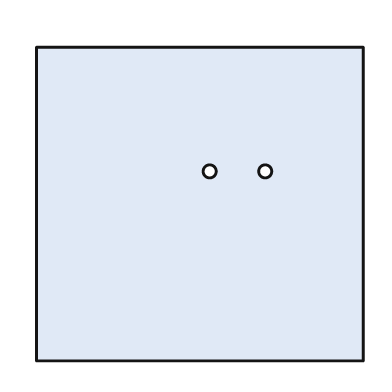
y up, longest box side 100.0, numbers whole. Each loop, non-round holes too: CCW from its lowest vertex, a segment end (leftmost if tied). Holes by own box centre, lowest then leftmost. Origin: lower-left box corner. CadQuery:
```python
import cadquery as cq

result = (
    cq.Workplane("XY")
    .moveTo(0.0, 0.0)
    .lineTo(100.0, 0.0)
    .lineTo(100.0, 96.0)
    .lineTo(0.0, 96.0)
    .close()
    .moveTo(53.0, 58.0)
    .circle(2.0)
    .moveTo(70.0, 58.0)
    .circle(2.0)
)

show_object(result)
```